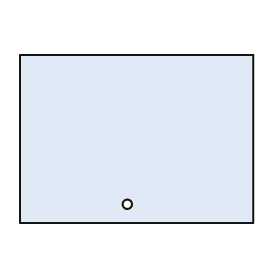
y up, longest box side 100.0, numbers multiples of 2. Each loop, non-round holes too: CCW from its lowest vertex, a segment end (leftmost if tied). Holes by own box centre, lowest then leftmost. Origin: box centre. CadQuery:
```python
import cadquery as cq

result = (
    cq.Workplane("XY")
    .moveTo(-50.0, -36.0)
    .lineTo(50.0, -36.0)
    .lineTo(50.0, 36.0)
    .lineTo(-50.0, 36.0)
    .close()
    .moveTo(-4.0, -28.0)
    .circle(2.0)
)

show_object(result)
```